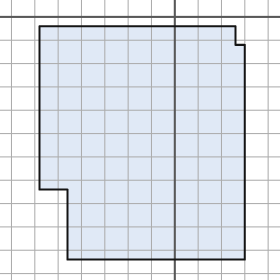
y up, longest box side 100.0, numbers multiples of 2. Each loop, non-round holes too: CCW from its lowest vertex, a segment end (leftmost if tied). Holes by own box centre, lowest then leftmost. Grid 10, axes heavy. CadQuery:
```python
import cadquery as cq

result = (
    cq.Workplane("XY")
    .moveTo(-46.0, -104.0)
    .lineTo(30.0, -104.0)
    .lineTo(30.0, -12.0)
    .lineTo(26.0, -12.0)
    .lineTo(26.0, -4.0)
    .lineTo(-58.0, -4.0)
    .lineTo(-58.0, -74.0)
    .lineTo(-46.0, -74.0)
    .close()
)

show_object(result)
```